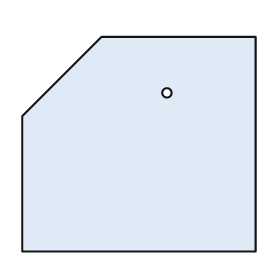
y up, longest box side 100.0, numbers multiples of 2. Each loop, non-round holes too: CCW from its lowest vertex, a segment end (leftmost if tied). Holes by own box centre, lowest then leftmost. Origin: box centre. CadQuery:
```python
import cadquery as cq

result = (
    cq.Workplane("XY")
    .moveTo(-50.0, -46.0)
    .lineTo(50.0, -46.0)
    .lineTo(50.0, 46.0)
    .lineTo(-16.0, 46.0)
    .lineTo(-50.0, 12.0)
    .close()
    .moveTo(12.0, 22.0)
    .circle(2.0)
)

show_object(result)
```